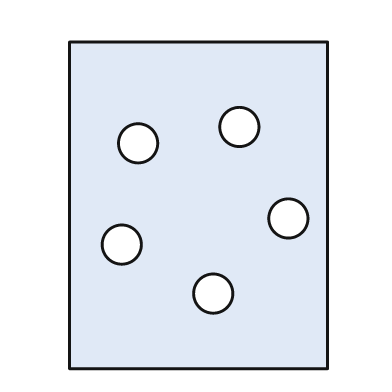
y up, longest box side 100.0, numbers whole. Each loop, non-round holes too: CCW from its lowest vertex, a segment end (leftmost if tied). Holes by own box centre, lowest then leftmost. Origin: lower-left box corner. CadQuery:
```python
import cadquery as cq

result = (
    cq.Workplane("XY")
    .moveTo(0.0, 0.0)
    .lineTo(79.0, 0.0)
    .lineTo(79.0, 100.0)
    .lineTo(0.0, 100.0)
    .close()
    .moveTo(44.0, 23.0)
    .circle(6.0)
    .moveTo(16.0, 38.0)
    .circle(6.0)
    .moveTo(67.0, 46.0)
    .circle(6.0)
    .moveTo(21.0, 69.0)
    .circle(6.0)
    .moveTo(52.0, 74.0)
    .circle(6.0)
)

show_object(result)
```